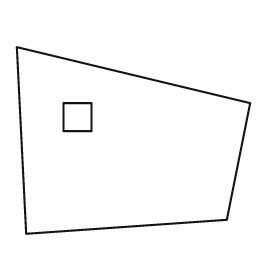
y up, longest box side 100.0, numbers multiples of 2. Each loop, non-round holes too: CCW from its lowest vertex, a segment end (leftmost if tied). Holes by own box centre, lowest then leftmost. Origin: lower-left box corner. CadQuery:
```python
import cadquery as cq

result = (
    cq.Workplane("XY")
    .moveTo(4.0, 0.0)
    .lineTo(90.0, 6.0)
    .lineTo(100.0, 56.0)
    .lineTo(0.0, 80.0)
    .close()
    .moveTo(20.0, 44.0)
    .lineTo(32.0, 44.0)
    .lineTo(32.0, 56.0)
    .lineTo(20.0, 56.0)
    .close()
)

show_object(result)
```